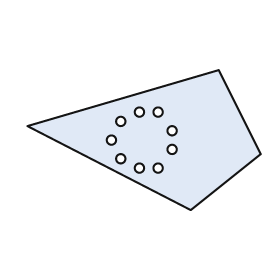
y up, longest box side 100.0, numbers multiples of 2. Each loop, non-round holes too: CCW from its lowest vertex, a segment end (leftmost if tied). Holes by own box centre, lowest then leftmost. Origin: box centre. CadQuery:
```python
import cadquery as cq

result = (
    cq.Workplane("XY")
    .moveTo(20.0, -30.0)
    .lineTo(50.0, -6.0)
    .lineTo(32.0, 30.0)
    .lineTo(-50.0, 6.0)
    .close()
    .moveTo(-2.0, -12.0)
    .circle(2.0)
    .moveTo(6.0, -12.0)
    .circle(2.0)
    .moveTo(-10.0, -8.0)
    .circle(2.0)
    .moveTo(12.0, -4.0)
    .circle(2.0)
    .moveTo(-14.0, 0.0)
    .circle(2.0)
    .moveTo(12.0, 4.0)
    .circle(2.0)
    .moveTo(-10.0, 8.0)
    .circle(2.0)
    .moveTo(-2.0, 12.0)
    .circle(2.0)
    .moveTo(6.0, 12.0)
    .circle(2.0)
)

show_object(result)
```